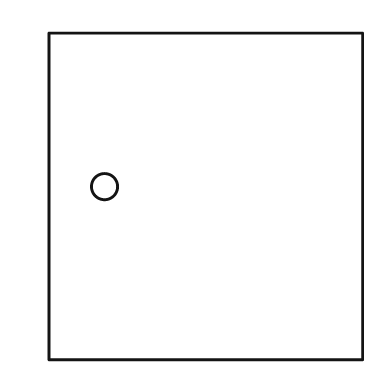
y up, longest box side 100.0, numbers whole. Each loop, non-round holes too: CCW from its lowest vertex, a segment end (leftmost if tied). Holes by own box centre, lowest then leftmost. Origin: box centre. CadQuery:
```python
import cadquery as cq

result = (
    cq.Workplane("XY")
    .moveTo(-48.0, -50.0)
    .lineTo(48.0, -50.0)
    .lineTo(48.0, 50.0)
    .lineTo(-48.0, 50.0)
    .close()
    .moveTo(-31.0, 3.0)
    .circle(4.0)
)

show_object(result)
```